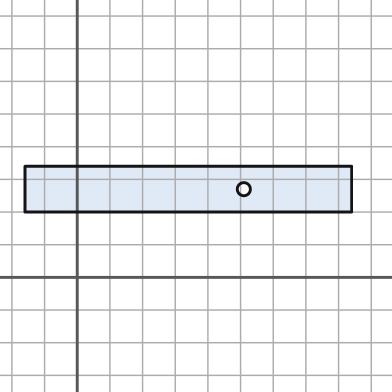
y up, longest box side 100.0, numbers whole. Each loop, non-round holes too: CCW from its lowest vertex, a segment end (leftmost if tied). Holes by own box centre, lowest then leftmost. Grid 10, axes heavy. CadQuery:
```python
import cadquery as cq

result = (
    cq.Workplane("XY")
    .moveTo(-16.0, 20.0)
    .lineTo(84.0, 20.0)
    .lineTo(84.0, 34.0)
    .lineTo(-16.0, 34.0)
    .close()
    .moveTo(51.0, 27.0)
    .circle(2.0)
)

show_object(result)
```